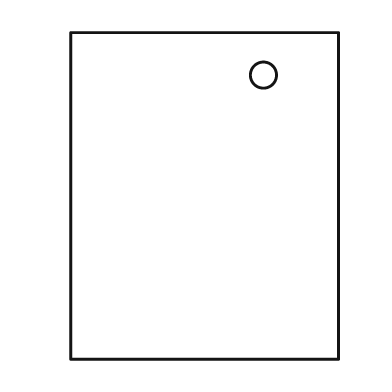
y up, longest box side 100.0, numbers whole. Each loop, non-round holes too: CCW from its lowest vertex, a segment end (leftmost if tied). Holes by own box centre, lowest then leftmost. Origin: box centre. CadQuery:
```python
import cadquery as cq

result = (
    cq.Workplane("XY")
    .moveTo(-41.0, -50.0)
    .lineTo(41.0, -50.0)
    .lineTo(41.0, 50.0)
    .lineTo(-41.0, 50.0)
    .close()
    .moveTo(18.0, 37.0)
    .circle(4.0)
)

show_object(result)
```